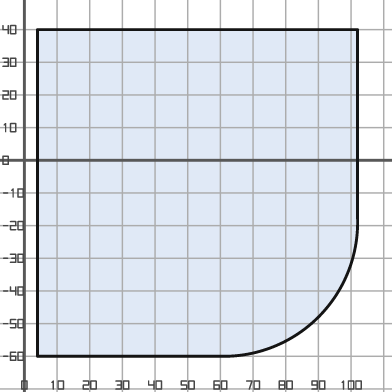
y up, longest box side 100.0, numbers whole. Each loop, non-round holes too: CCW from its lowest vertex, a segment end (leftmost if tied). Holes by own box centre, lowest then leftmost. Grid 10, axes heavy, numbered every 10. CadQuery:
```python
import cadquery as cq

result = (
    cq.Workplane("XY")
    .moveTo(4.0, -60.0)
    .lineTo(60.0, -60.0)
    .threePointArc((90.0, -48.0), (102.0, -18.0))
    .lineTo(102.0, 40.0)
    .lineTo(4.0, 40.0)
    .close()
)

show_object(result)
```